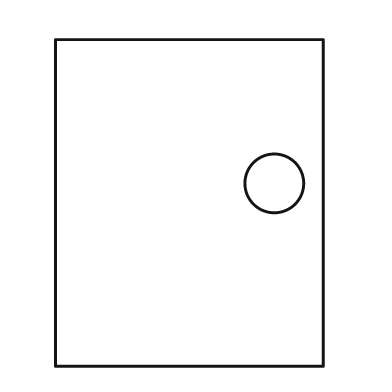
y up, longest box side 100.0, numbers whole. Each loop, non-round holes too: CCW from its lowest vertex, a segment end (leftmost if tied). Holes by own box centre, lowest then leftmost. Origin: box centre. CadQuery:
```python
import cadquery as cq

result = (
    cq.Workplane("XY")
    .moveTo(-41.0, -50.0)
    .lineTo(41.0, -50.0)
    .lineTo(41.0, 50.0)
    .lineTo(-41.0, 50.0)
    .close()
    .moveTo(26.0, 6.0)
    .circle(9.0)
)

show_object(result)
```